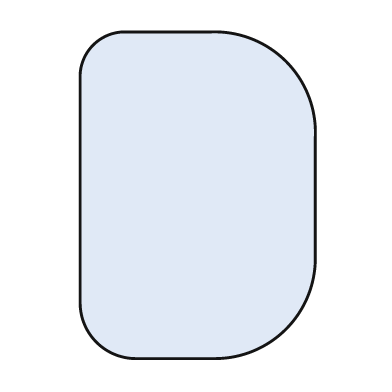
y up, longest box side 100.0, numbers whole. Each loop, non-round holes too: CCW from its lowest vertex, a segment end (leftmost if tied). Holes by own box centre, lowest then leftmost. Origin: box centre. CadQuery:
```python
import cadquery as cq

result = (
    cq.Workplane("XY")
    .moveTo(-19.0, -50.0)
    .lineTo(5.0, -50.0)
    .threePointArc((27.0, -41.0), (36.0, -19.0))
    .lineTo(36.0, 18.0)
    .threePointArc((27.0, 41.0), (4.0, 50.0))
    .lineTo(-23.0, 50.0)
    .threePointArc((-32.0, 46.0), (-36.0, 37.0))
    .lineTo(-36.0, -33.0)
    .threePointArc((-31.0, -45.0), (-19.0, -50.0))
    .close()
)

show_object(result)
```